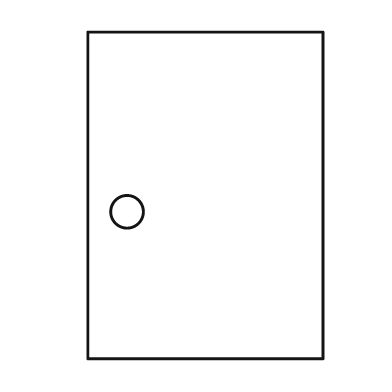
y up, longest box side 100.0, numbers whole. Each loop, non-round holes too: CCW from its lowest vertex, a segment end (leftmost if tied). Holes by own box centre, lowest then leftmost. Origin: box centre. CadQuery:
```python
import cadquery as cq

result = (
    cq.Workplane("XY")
    .moveTo(-36.0, -50.0)
    .lineTo(36.0, -50.0)
    .lineTo(36.0, 50.0)
    .lineTo(-36.0, 50.0)
    .close()
    .moveTo(-24.0, -5.0)
    .circle(5.0)
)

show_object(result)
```